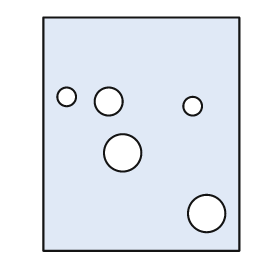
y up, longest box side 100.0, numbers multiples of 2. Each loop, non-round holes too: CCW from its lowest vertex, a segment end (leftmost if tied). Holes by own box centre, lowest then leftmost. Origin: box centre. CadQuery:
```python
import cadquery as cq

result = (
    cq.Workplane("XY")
    .moveTo(-42.0, -50.0)
    .lineTo(42.0, -50.0)
    .lineTo(42.0, 50.0)
    .lineTo(-42.0, 50.0)
    .close()
    .moveTo(28.0, -34.0)
    .circle(8.0)
    .moveTo(-8.0, -8.0)
    .circle(8.0)
    .moveTo(22.0, 12.0)
    .circle(4.0)
    .moveTo(-14.0, 14.0)
    .circle(6.0)
    .moveTo(-32.0, 16.0)
    .circle(4.0)
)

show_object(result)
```